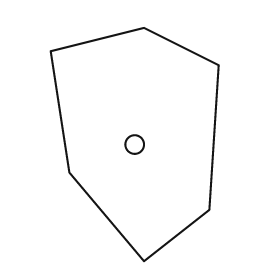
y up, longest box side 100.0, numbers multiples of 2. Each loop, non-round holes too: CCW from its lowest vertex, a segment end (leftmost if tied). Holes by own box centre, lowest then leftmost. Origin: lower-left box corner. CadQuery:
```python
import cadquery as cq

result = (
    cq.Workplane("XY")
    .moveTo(40.0, 0.0)
    .lineTo(68.0, 22.0)
    .lineTo(72.0, 84.0)
    .lineTo(40.0, 100.0)
    .lineTo(0.0, 90.0)
    .lineTo(8.0, 38.0)
    .close()
    .moveTo(36.0, 50.0)
    .circle(4.0)
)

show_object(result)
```